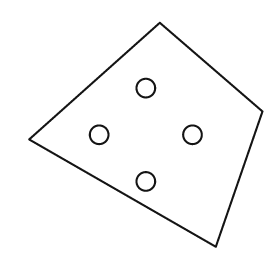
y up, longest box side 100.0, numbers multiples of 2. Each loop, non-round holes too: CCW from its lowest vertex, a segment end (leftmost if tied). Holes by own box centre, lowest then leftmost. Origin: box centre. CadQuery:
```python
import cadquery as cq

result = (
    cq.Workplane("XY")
    .moveTo(30.0, -48.0)
    .lineTo(50.0, 10.0)
    .lineTo(6.0, 48.0)
    .lineTo(-50.0, -2.0)
    .close()
    .moveTo(0.0, -20.0)
    .circle(4.0)
    .moveTo(-20.0, 0.0)
    .circle(4.0)
    .moveTo(20.0, 0.0)
    .circle(4.0)
    .moveTo(0.0, 20.0)
    .circle(4.0)
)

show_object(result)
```